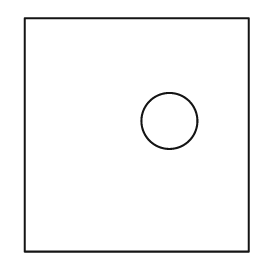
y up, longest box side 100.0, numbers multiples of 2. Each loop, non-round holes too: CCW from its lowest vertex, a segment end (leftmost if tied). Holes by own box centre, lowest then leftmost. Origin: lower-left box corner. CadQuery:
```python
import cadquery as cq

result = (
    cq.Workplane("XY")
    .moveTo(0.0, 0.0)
    .lineTo(96.0, 0.0)
    .lineTo(96.0, 100.0)
    .lineTo(0.0, 100.0)
    .close()
    .moveTo(62.0, 56.0)
    .circle(12.0)
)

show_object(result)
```